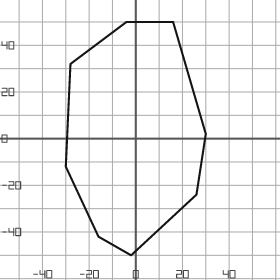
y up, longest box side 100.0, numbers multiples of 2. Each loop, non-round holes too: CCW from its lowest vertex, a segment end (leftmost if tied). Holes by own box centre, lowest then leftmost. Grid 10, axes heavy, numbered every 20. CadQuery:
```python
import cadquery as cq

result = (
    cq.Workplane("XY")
    .moveTo(-2.0, -50.0)
    .lineTo(26.0, -24.0)
    .lineTo(30.0, 2.0)
    .lineTo(16.0, 50.0)
    .lineTo(-4.0, 50.0)
    .lineTo(-28.0, 32.0)
    .lineTo(-30.0, -12.0)
    .lineTo(-16.0, -42.0)
    .close()
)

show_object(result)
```